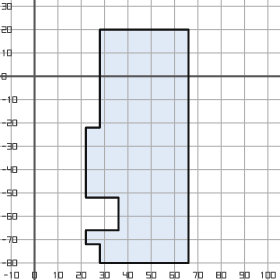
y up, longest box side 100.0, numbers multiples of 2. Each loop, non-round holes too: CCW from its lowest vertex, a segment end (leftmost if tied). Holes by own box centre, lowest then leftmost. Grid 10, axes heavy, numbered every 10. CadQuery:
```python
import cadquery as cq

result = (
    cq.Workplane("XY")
    .moveTo(28.0, -80.0)
    .lineTo(66.0, -80.0)
    .lineTo(66.0, 20.0)
    .lineTo(28.0, 20.0)
    .lineTo(28.0, -22.0)
    .lineTo(22.0, -22.0)
    .lineTo(22.0, -52.0)
    .lineTo(36.0, -52.0)
    .lineTo(36.0, -66.0)
    .lineTo(22.0, -66.0)
    .lineTo(22.0, -72.0)
    .lineTo(28.0, -72.0)
    .close()
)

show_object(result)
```